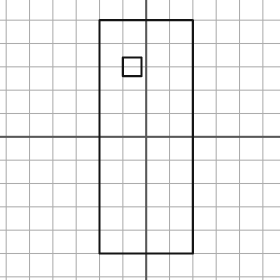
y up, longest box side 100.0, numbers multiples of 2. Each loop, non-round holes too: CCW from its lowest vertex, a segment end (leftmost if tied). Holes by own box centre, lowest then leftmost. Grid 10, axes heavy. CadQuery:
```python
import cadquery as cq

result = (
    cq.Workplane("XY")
    .moveTo(-20.0, -50.0)
    .lineTo(20.0, -50.0)
    .lineTo(20.0, 50.0)
    .lineTo(-20.0, 50.0)
    .close()
    .moveTo(-10.0, 26.0)
    .lineTo(-2.0, 26.0)
    .lineTo(-2.0, 34.0)
    .lineTo(-10.0, 34.0)
    .close()
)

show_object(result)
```